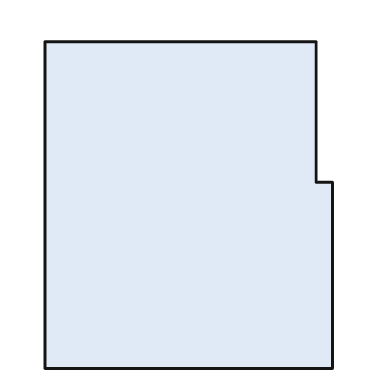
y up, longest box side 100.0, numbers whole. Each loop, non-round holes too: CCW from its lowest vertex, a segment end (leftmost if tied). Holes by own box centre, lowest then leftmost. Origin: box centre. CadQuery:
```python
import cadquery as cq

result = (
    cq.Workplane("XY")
    .moveTo(-44.0, -50.0)
    .lineTo(44.0, -50.0)
    .lineTo(44.0, 7.0)
    .lineTo(39.0, 7.0)
    .lineTo(39.0, 50.0)
    .lineTo(-44.0, 50.0)
    .close()
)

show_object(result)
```